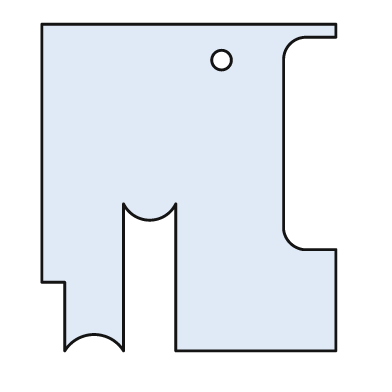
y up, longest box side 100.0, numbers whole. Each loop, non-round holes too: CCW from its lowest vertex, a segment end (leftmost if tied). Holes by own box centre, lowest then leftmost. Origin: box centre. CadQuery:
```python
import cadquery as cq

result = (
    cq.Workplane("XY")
    .moveTo(-38.0, -50.0)
    .threePointArc((-29.0, -45.0), (-20.0, -50.0))
    .lineTo(-20.0, -5.0)
    .threePointArc((-12.0, -10.0), (-4.0, -5.0))
    .lineTo(-4.0, -50.0)
    .lineTo(45.0, -50.0)
    .lineTo(45.0, -19.0)
    .lineTo(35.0, -19.0)
    .threePointArc((31.0, -17.0), (29.0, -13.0))
    .lineTo(29.0, 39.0)
    .threePointArc((31.0, 44.0), (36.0, 46.0))
    .lineTo(45.0, 46.0)
    .lineTo(45.0, 50.0)
    .lineTo(-45.0, 50.0)
    .lineTo(-45.0, -29.0)
    .lineTo(-38.0, -29.0)
    .close()
    .moveTo(10.0, 39.0)
    .circle(3.0)
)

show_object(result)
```